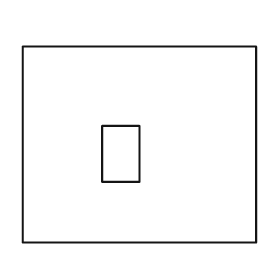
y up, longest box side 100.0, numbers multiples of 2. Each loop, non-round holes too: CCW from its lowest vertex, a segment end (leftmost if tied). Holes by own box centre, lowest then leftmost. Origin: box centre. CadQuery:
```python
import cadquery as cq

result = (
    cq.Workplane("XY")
    .moveTo(-50.0, -42.0)
    .lineTo(50.0, -42.0)
    .lineTo(50.0, 42.0)
    .lineTo(-50.0, 42.0)
    .close()
    .moveTo(-16.0, -16.0)
    .lineTo(0.0, -16.0)
    .lineTo(0.0, 8.0)
    .lineTo(-16.0, 8.0)
    .close()
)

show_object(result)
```